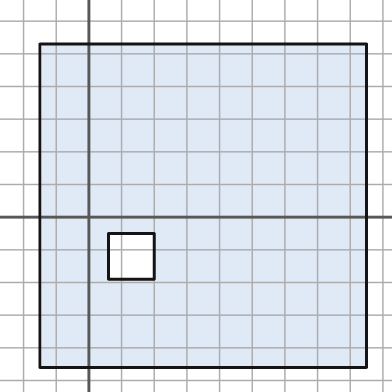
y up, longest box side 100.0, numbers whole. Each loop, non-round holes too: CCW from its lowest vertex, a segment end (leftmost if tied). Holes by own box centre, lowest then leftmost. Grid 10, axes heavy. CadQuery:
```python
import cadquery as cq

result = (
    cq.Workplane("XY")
    .moveTo(-15.0, -46.0)
    .lineTo(85.0, -46.0)
    .lineTo(85.0, 53.0)
    .lineTo(-15.0, 53.0)
    .close()
    .moveTo(6.0, -19.0)
    .lineTo(20.0, -19.0)
    .lineTo(20.0, -5.0)
    .lineTo(6.0, -5.0)
    .close()
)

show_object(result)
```